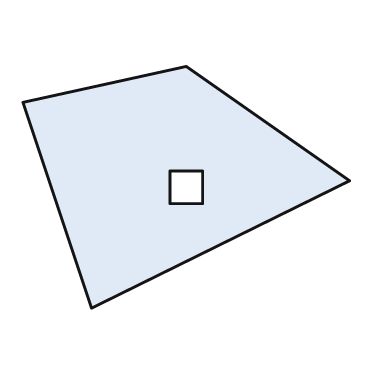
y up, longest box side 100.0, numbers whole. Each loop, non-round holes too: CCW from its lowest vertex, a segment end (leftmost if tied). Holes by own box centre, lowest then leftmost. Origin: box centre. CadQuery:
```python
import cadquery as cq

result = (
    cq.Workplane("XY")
    .moveTo(-29.0, -37.0)
    .lineTo(50.0, 2.0)
    .lineTo(0.0, 37.0)
    .lineTo(-50.0, 26.0)
    .close()
    .moveTo(-5.0, -5.0)
    .lineTo(5.0, -5.0)
    .lineTo(5.0, 5.0)
    .lineTo(-5.0, 5.0)
    .close()
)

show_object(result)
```